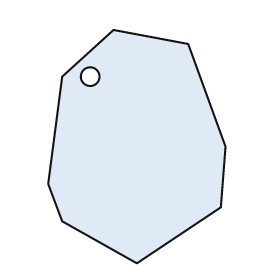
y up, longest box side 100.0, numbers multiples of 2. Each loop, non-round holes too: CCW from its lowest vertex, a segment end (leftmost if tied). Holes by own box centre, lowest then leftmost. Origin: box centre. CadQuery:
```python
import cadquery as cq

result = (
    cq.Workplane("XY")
    .moveTo(0.0, -50.0)
    .lineTo(36.0, -26.0)
    .lineTo(38.0, 0.0)
    .lineTo(22.0, 44.0)
    .lineTo(-10.0, 50.0)
    .lineTo(-32.0, 30.0)
    .lineTo(-38.0, -16.0)
    .lineTo(-32.0, -32.0)
    .close()
    .moveTo(-20.0, 30.0)
    .circle(4.0)
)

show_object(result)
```